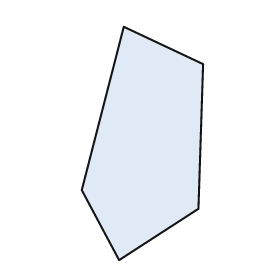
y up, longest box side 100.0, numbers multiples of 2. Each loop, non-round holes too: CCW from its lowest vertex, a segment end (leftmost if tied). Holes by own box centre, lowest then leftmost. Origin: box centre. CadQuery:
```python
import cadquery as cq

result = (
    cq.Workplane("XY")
    .moveTo(-10.0, -50.0)
    .lineTo(24.0, -28.0)
    .lineTo(26.0, 34.0)
    .lineTo(-8.0, 50.0)
    .lineTo(-26.0, -20.0)
    .close()
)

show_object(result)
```